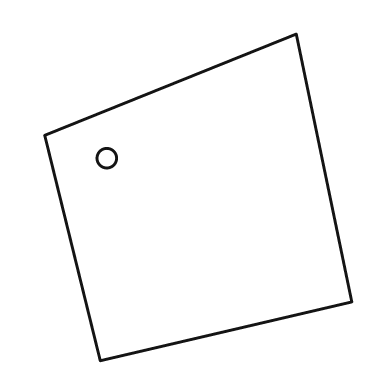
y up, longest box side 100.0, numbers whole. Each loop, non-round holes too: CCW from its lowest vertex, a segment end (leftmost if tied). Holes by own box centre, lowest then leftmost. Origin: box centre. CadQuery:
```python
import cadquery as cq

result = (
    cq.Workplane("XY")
    .moveTo(-30.0, -50.0)
    .lineTo(47.0, -32.0)
    .lineTo(30.0, 50.0)
    .lineTo(-47.0, 19.0)
    .close()
    .moveTo(-28.0, 12.0)
    .circle(3.0)
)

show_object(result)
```